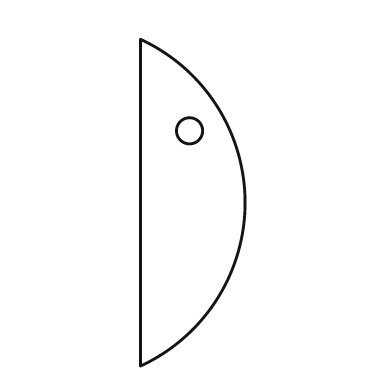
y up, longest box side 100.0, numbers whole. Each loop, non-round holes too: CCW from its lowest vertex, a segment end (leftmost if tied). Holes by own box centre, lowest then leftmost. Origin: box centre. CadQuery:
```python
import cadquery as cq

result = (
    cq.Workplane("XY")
    .moveTo(-16.0, -50.0)
    .threePointArc((16.0, 0.0), (-16.0, 50.0))
    .close()
    .moveTo(-1.0, 22.0)
    .circle(4.0)
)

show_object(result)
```